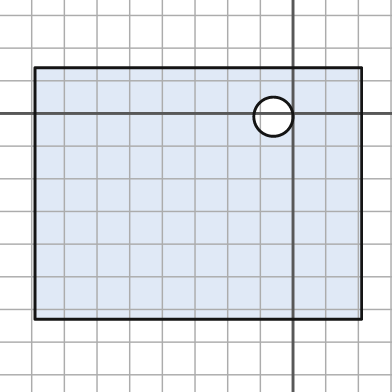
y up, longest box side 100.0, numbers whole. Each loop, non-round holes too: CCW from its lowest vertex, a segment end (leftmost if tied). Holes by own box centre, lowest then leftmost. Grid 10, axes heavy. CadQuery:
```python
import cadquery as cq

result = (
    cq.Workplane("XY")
    .moveTo(-79.0, -63.0)
    .lineTo(21.0, -63.0)
    .lineTo(21.0, 14.0)
    .lineTo(-79.0, 14.0)
    .close()
    .moveTo(-6.0, -1.0)
    .circle(6.0)
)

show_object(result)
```